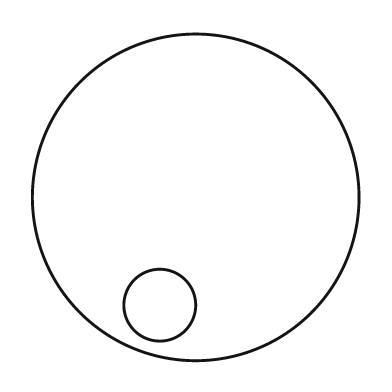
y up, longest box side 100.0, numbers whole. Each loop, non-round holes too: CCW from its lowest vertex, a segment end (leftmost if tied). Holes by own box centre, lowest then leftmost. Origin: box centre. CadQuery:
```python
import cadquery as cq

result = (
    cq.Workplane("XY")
    .moveTo(0.0, 0.0)
    .circle(50.0)
    .moveTo(-11.0, -33.0)
    .circle(11.0)
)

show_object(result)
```